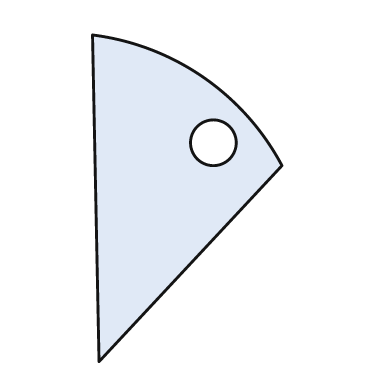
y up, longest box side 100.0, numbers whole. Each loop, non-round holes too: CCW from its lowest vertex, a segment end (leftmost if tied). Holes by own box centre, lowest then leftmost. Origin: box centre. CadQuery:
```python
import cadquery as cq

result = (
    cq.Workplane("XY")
    .moveTo(-27.0, -50.0)
    .lineTo(29.0, 10.0)
    .threePointArc((5.0, 37.0), (-29.0, 50.0))
    .close()
    .moveTo(8.0, 17.0)
    .circle(7.0)
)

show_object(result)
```